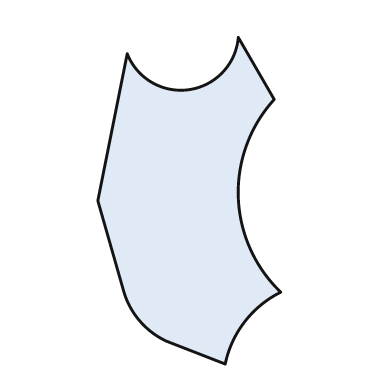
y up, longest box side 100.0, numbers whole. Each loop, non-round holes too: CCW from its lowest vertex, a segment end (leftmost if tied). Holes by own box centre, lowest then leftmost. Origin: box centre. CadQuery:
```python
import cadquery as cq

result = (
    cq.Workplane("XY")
    .moveTo(11.0, -50.0)
    .threePointArc((17.0, -37.0), (28.0, -28.0))
    .threePointArc((15.0, 1.0), (26.0, 31.0))
    .lineTo(15.0, 50.0)
    .threePointArc((0.0, 34.0), (-19.0, 45.0))
    .lineTo(-28.0, 0.0)
    .lineTo(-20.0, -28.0)
    .threePointArc((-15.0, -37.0), (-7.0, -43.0))
    .close()
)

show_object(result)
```